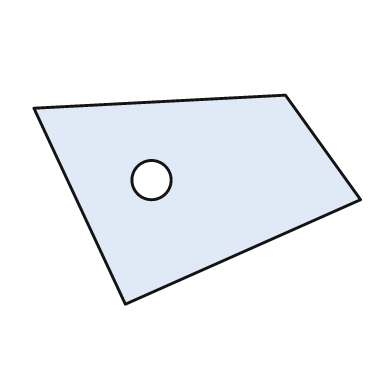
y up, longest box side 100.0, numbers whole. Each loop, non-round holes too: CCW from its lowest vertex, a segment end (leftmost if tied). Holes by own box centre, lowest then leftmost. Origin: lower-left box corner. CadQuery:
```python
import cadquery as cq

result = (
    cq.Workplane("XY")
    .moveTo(28.0, 0.0)
    .lineTo(100.0, 32.0)
    .lineTo(77.0, 64.0)
    .lineTo(0.0, 60.0)
    .close()
    .moveTo(36.0, 38.0)
    .circle(6.0)
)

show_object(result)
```